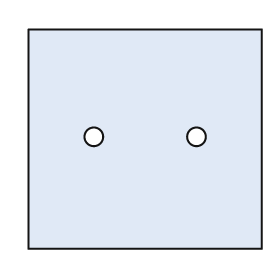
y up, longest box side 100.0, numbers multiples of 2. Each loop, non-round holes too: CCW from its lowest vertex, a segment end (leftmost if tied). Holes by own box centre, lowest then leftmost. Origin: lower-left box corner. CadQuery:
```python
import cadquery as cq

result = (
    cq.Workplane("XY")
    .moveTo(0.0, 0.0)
    .lineTo(100.0, 0.0)
    .lineTo(100.0, 94.0)
    .lineTo(0.0, 94.0)
    .close()
    .moveTo(28.0, 48.0)
    .circle(4.0)
    .moveTo(72.0, 48.0)
    .circle(4.0)
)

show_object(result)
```